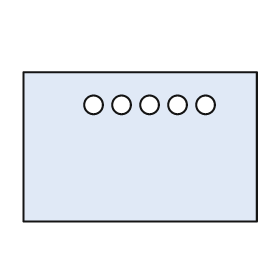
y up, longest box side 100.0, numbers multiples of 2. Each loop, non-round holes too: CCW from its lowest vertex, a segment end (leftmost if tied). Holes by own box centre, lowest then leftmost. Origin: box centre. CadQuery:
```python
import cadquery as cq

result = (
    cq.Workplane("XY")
    .moveTo(-50.0, -32.0)
    .lineTo(50.0, -32.0)
    .lineTo(50.0, 32.0)
    .lineTo(-50.0, 32.0)
    .close()
    .moveTo(-20.0, 18.0)
    .circle(4.0)
    .moveTo(-8.0, 18.0)
    .circle(4.0)
    .moveTo(4.0, 18.0)
    .circle(4.0)
    .moveTo(16.0, 18.0)
    .circle(4.0)
    .moveTo(28.0, 18.0)
    .circle(4.0)
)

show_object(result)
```